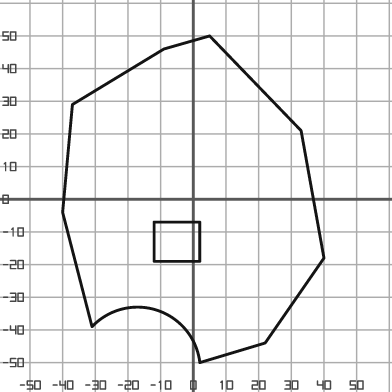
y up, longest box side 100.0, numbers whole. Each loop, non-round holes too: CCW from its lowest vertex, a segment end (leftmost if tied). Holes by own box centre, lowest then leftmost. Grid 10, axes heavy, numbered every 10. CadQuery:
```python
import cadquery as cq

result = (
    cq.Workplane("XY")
    .moveTo(2.0, -50.0)
    .lineTo(22.0, -44.0)
    .lineTo(40.0, -18.0)
    .lineTo(33.0, 21.0)
    .lineTo(5.0, 50.0)
    .lineTo(-9.0, 46.0)
    .lineTo(-37.0, 29.0)
    .lineTo(-40.0, -4.0)
    .lineTo(-31.0, -39.0)
    .threePointArc((-11.0, -34.0), (2.0, -50.0))
    .close()
    .moveTo(-12.0, -19.0)
    .lineTo(2.0, -19.0)
    .lineTo(2.0, -7.0)
    .lineTo(-12.0, -7.0)
    .close()
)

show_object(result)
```